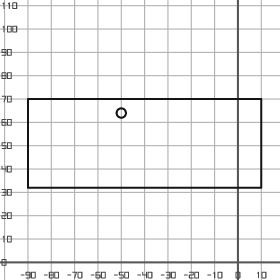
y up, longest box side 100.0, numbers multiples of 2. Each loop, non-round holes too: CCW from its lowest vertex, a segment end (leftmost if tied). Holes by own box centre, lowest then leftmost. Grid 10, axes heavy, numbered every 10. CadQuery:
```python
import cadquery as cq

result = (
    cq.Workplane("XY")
    .moveTo(-90.0, 32.0)
    .lineTo(10.0, 32.0)
    .lineTo(10.0, 70.0)
    .lineTo(-90.0, 70.0)
    .close()
    .moveTo(-50.0, 64.0)
    .circle(2.0)
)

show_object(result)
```